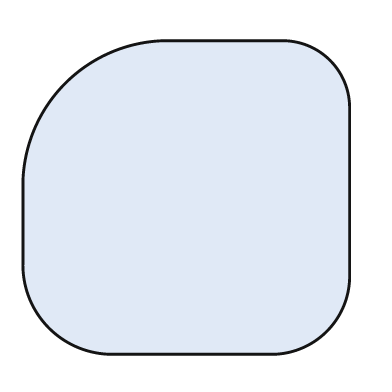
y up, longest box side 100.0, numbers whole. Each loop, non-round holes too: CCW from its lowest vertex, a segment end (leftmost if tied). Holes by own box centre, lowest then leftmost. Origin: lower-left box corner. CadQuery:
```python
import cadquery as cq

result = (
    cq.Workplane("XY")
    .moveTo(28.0, 0.0)
    .lineTo(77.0, 0.0)
    .threePointArc((93.0, 7.0), (100.0, 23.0))
    .lineTo(100.0, 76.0)
    .threePointArc((94.0, 90.0), (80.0, 96.0))
    .lineTo(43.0, 96.0)
    .threePointArc((13.0, 83.0), (0.0, 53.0))
    .lineTo(0.0, 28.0)
    .threePointArc((8.0, 8.0), (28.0, 0.0))
    .close()
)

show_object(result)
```